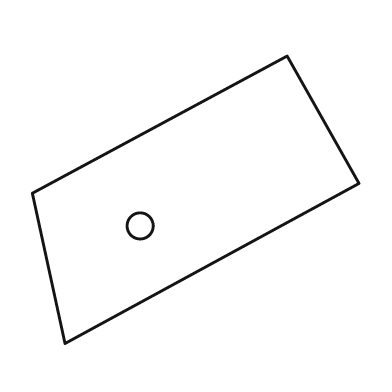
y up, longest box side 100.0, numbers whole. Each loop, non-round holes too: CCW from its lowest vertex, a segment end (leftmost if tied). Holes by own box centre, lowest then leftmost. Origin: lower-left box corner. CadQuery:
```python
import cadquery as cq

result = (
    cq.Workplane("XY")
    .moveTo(10.0, 0.0)
    .lineTo(100.0, 49.0)
    .lineTo(78.0, 88.0)
    .lineTo(0.0, 46.0)
    .close()
    .moveTo(33.0, 36.0)
    .circle(4.0)
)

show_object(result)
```